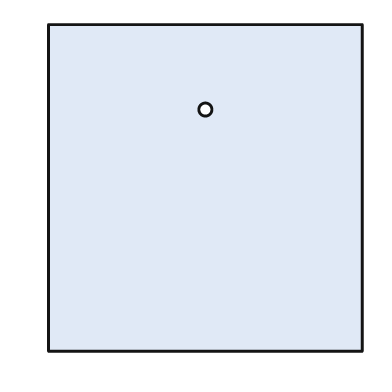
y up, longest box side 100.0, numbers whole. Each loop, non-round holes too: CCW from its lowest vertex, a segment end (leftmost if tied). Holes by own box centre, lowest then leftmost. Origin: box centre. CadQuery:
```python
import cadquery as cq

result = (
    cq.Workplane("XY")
    .moveTo(-48.0, -50.0)
    .lineTo(48.0, -50.0)
    .lineTo(48.0, 50.0)
    .lineTo(-48.0, 50.0)
    .close()
    .moveTo(0.0, 24.0)
    .circle(2.0)
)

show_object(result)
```